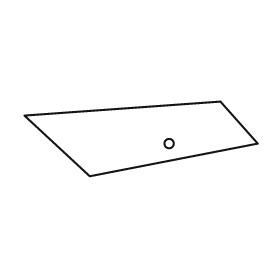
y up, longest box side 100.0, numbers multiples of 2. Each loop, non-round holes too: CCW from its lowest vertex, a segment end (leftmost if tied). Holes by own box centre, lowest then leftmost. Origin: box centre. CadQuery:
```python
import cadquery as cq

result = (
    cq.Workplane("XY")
    .moveTo(-22.0, -16.0)
    .lineTo(50.0, -2.0)
    .lineTo(34.0, 16.0)
    .lineTo(-50.0, 10.0)
    .close()
    .moveTo(12.0, -2.0)
    .circle(2.0)
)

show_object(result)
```